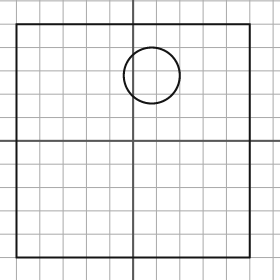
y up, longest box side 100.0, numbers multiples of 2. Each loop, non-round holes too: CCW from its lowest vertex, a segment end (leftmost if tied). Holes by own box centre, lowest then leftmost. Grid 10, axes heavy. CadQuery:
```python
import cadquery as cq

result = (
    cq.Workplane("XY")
    .moveTo(-50.0, -50.0)
    .lineTo(50.0, -50.0)
    .lineTo(50.0, 50.0)
    .lineTo(-50.0, 50.0)
    .close()
    .moveTo(8.0, 28.0)
    .circle(12.0)
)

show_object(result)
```